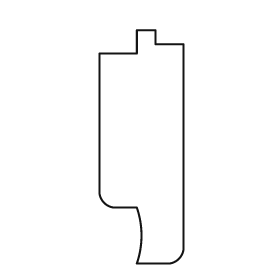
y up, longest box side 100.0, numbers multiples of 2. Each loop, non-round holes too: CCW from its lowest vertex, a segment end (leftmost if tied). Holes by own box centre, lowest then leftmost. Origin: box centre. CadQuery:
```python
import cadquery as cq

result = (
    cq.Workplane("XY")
    .moveTo(-2.0, -50.0)
    .lineTo(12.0, -50.0)
    .threePointArc((16.0, -48.0), (18.0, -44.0))
    .lineTo(18.0, 44.0)
    .lineTo(6.0, 44.0)
    .lineTo(6.0, 50.0)
    .lineTo(-2.0, 50.0)
    .lineTo(-2.0, 40.0)
    .lineTo(-18.0, 40.0)
    .lineTo(-18.0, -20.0)
    .threePointArc((-16.0, -24.0), (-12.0, -26.0))
    .lineTo(-2.0, -26.0)
    .threePointArc((0.0, -38.0), (-2.0, -50.0))
    .close()
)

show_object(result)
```